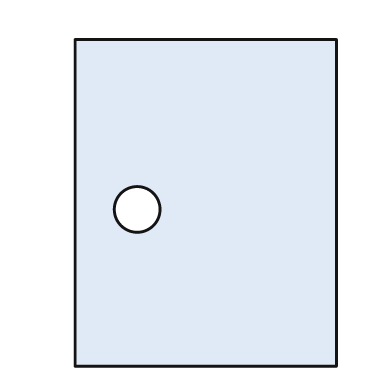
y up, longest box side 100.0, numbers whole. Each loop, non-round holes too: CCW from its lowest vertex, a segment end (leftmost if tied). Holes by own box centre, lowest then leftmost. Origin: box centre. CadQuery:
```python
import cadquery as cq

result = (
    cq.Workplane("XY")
    .moveTo(-40.0, -50.0)
    .lineTo(40.0, -50.0)
    .lineTo(40.0, 50.0)
    .lineTo(-40.0, 50.0)
    .close()
    .moveTo(-21.0, -2.0)
    .circle(7.0)
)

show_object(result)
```